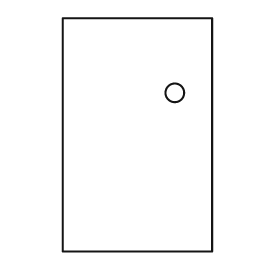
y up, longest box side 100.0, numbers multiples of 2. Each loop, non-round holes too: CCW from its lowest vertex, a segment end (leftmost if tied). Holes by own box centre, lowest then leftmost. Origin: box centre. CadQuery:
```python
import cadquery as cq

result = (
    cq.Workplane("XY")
    .moveTo(-32.0, -50.0)
    .lineTo(32.0, -50.0)
    .lineTo(32.0, 50.0)
    .lineTo(-32.0, 50.0)
    .close()
    .moveTo(16.0, 18.0)
    .circle(4.0)
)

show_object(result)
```